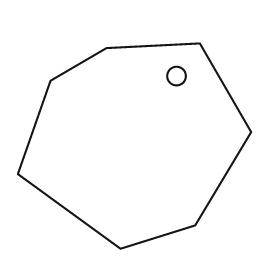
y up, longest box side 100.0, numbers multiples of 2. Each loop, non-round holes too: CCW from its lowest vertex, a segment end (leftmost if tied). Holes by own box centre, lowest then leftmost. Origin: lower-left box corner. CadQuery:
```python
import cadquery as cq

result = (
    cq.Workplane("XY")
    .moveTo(44.0, 0.0)
    .lineTo(76.0, 10.0)
    .lineTo(100.0, 50.0)
    .lineTo(78.0, 88.0)
    .lineTo(38.0, 86.0)
    .lineTo(14.0, 72.0)
    .lineTo(0.0, 32.0)
    .close()
    .moveTo(68.0, 74.0)
    .circle(4.0)
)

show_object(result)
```